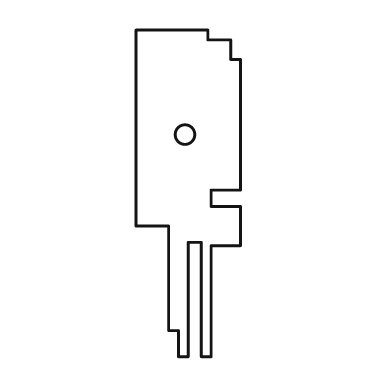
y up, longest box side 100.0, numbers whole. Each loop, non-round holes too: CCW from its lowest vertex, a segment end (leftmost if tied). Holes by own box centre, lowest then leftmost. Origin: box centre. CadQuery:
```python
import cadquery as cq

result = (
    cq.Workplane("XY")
    .moveTo(-3.0, -50.0)
    .lineTo(0.0, -50.0)
    .lineTo(0.0, -15.0)
    .lineTo(4.0, -15.0)
    .lineTo(4.0, -50.0)
    .lineTo(7.0, -50.0)
    .lineTo(7.0, -16.0)
    .lineTo(16.0, -16.0)
    .lineTo(16.0, -4.0)
    .lineTo(7.0, -4.0)
    .lineTo(7.0, 1.0)
    .lineTo(16.0, 1.0)
    .lineTo(16.0, 41.0)
    .lineTo(13.0, 41.0)
    .lineTo(13.0, 47.0)
    .lineTo(6.0, 47.0)
    .lineTo(6.0, 50.0)
    .lineTo(-16.0, 50.0)
    .lineTo(-16.0, -10.0)
    .lineTo(-6.0, -10.0)
    .lineTo(-6.0, -42.0)
    .lineTo(-3.0, -42.0)
    .close()
    .moveTo(-1.0, 18.0)
    .circle(3.0)
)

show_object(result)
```